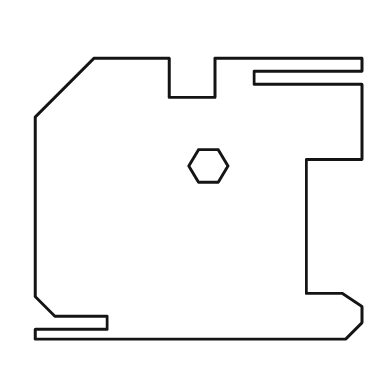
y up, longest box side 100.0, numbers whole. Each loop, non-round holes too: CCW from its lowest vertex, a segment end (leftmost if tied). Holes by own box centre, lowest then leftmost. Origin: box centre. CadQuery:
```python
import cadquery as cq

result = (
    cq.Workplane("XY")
    .moveTo(-50.0, -43.0)
    .lineTo(45.0, -43.0)
    .lineTo(50.0, -38.0)
    .lineTo(50.0, -33.0)
    .lineTo(44.0, -29.0)
    .lineTo(33.0, -29.0)
    .lineTo(33.0, 12.0)
    .lineTo(50.0, 12.0)
    .lineTo(50.0, 35.0)
    .lineTo(17.0, 35.0)
    .lineTo(17.0, 39.0)
    .lineTo(50.0, 39.0)
    .lineTo(50.0, 43.0)
    .lineTo(5.0, 43.0)
    .lineTo(5.0, 31.0)
    .lineTo(-9.0, 31.0)
    .lineTo(-9.0, 43.0)
    .lineTo(-32.0, 43.0)
    .lineTo(-50.0, 25.0)
    .lineTo(-50.0, -30.0)
    .lineTo(-44.0, -36.0)
    .lineTo(-28.0, -36.0)
    .lineTo(-28.0, -40.0)
    .lineTo(-50.0, -40.0)
    .close()
    .moveTo(0.0, 5.0)
    .lineTo(6.0, 5.0)
    .lineTo(9.0, 10.0)
    .lineTo(6.0, 15.0)
    .lineTo(0.0, 15.0)
    .lineTo(-3.0, 10.0)
    .close()
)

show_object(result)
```